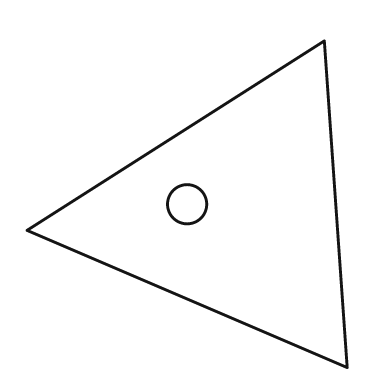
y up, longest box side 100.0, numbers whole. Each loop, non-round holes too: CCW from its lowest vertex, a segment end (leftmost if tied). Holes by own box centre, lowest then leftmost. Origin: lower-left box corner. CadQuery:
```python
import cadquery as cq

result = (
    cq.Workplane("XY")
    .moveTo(98.0, 0.0)
    .lineTo(91.0, 100.0)
    .lineTo(0.0, 42.0)
    .close()
    .moveTo(49.0, 50.0)
    .circle(6.0)
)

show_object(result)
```